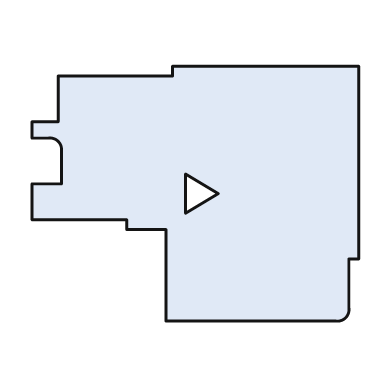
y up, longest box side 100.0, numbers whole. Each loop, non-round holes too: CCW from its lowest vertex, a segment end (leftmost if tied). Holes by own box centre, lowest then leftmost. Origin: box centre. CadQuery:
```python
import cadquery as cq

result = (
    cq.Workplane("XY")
    .moveTo(-9.0, -39.0)
    .lineTo(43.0, -39.0)
    .threePointArc((46.0, -38.0), (47.0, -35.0))
    .lineTo(47.0, -20.0)
    .lineTo(50.0, -20.0)
    .lineTo(50.0, 39.0)
    .lineTo(-7.0, 39.0)
    .lineTo(-7.0, 36.0)
    .lineTo(-42.0, 36.0)
    .lineTo(-42.0, 22.0)
    .lineTo(-50.0, 22.0)
    .lineTo(-50.0, 17.0)
    .lineTo(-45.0, 17.0)
    .threePointArc((-42.0, 16.0), (-41.0, 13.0))
    .lineTo(-41.0, 3.0)
    .lineTo(-50.0, 3.0)
    .lineTo(-50.0, -8.0)
    .lineTo(-21.0, -8.0)
    .lineTo(-21.0, -11.0)
    .lineTo(-9.0, -11.0)
    .close()
    .moveTo(-3.0, -6.0)
    .lineTo(7.0, 0.0)
    .lineTo(-3.0, 6.0)
    .close()
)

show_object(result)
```